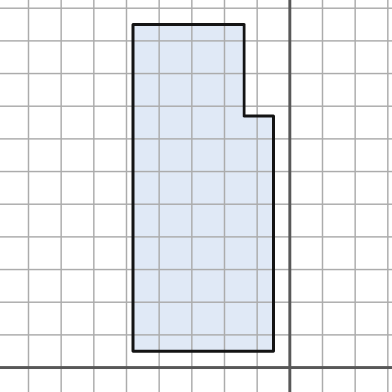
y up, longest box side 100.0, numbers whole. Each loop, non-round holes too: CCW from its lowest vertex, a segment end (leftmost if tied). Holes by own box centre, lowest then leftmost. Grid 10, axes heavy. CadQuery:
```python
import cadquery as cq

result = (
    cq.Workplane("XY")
    .moveTo(-48.0, 5.0)
    .lineTo(-5.0, 5.0)
    .lineTo(-5.0, 77.0)
    .lineTo(-14.0, 77.0)
    .lineTo(-14.0, 105.0)
    .lineTo(-48.0, 105.0)
    .close()
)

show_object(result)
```